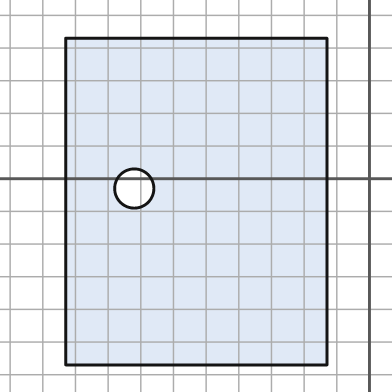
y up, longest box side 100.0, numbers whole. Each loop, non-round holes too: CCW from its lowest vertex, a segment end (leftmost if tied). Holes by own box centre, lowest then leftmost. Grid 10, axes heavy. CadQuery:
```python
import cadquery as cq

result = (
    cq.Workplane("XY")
    .moveTo(-93.0, -57.0)
    .lineTo(-13.0, -57.0)
    .lineTo(-13.0, 43.0)
    .lineTo(-93.0, 43.0)
    .close()
    .moveTo(-72.0, -3.0)
    .circle(6.0)
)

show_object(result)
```